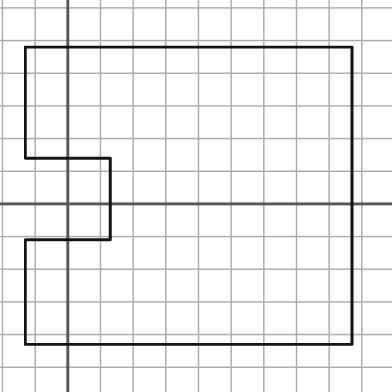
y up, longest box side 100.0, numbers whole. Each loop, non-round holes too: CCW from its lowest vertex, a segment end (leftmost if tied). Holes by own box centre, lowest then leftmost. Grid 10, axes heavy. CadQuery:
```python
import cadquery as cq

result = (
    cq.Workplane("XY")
    .moveTo(-13.0, -43.0)
    .lineTo(87.0, -43.0)
    .lineTo(87.0, 48.0)
    .lineTo(-13.0, 48.0)
    .lineTo(-13.0, 14.0)
    .lineTo(13.0, 14.0)
    .lineTo(13.0, -11.0)
    .lineTo(-13.0, -11.0)
    .close()
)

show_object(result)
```